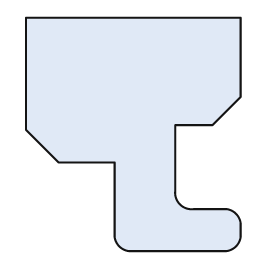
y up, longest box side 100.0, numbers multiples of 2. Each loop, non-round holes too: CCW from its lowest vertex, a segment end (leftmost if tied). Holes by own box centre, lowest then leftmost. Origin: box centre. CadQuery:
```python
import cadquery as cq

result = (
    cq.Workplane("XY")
    .moveTo(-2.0, -50.0)
    .lineTo(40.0, -50.0)
    .threePointArc((44.0, -48.0), (46.0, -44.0))
    .lineTo(46.0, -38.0)
    .threePointArc((44.0, -34.0), (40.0, -32.0))
    .lineTo(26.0, -32.0)
    .threePointArc((20.0, -30.0), (18.0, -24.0))
    .lineTo(18.0, 4.0)
    .lineTo(34.0, 4.0)
    .lineTo(46.0, 16.0)
    .lineTo(46.0, 50.0)
    .lineTo(-46.0, 50.0)
    .lineTo(-46.0, 2.0)
    .lineTo(-32.0, -12.0)
    .lineTo(-8.0, -12.0)
    .lineTo(-8.0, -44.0)
    .threePointArc((-6.0, -48.0), (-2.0, -50.0))
    .close()
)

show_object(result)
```